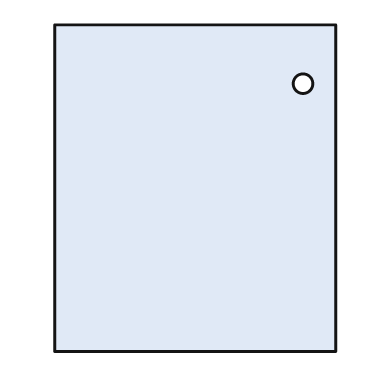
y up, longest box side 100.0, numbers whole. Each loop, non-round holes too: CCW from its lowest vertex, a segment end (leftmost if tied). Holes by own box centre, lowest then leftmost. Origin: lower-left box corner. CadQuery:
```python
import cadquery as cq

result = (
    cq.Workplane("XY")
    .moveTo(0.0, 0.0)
    .lineTo(86.0, 0.0)
    .lineTo(86.0, 100.0)
    .lineTo(0.0, 100.0)
    .close()
    .moveTo(76.0, 82.0)
    .circle(3.0)
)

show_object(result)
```